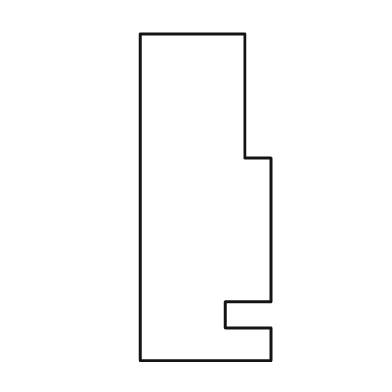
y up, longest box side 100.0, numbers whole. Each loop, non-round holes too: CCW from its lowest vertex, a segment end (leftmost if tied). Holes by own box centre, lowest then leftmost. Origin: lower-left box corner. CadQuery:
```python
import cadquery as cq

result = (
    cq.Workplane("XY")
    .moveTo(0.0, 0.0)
    .lineTo(40.0, 0.0)
    .lineTo(40.0, 10.0)
    .lineTo(26.0, 10.0)
    .lineTo(26.0, 18.0)
    .lineTo(40.0, 18.0)
    .lineTo(40.0, 62.0)
    .lineTo(32.0, 62.0)
    .lineTo(32.0, 100.0)
    .lineTo(0.0, 100.0)
    .close()
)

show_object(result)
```